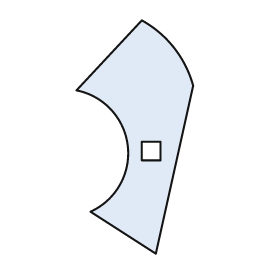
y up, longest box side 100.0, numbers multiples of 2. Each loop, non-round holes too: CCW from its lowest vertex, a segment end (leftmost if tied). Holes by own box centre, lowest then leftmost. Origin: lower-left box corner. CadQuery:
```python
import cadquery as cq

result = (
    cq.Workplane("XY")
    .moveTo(34.0, 0.0)
    .lineTo(50.0, 72.0)
    .threePointArc((42.0, 88.0), (28.0, 100.0))
    .lineTo(0.0, 70.0)
    .threePointArc((22.0, 46.0), (6.0, 18.0))
    .close()
    .moveTo(28.0, 40.0)
    .lineTo(36.0, 40.0)
    .lineTo(36.0, 48.0)
    .lineTo(28.0, 48.0)
    .close()
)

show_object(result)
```